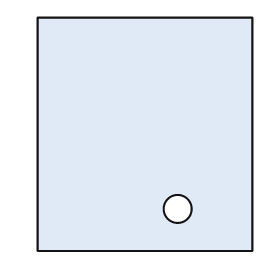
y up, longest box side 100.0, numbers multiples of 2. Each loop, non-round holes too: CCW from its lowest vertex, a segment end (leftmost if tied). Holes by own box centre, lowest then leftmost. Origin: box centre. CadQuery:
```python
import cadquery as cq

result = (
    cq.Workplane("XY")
    .moveTo(-46.0, -50.0)
    .lineTo(46.0, -50.0)
    .lineTo(46.0, 50.0)
    .lineTo(-46.0, 50.0)
    .close()
    .moveTo(14.0, -32.0)
    .circle(6.0)
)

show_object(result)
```